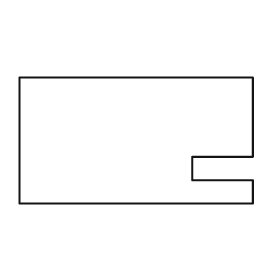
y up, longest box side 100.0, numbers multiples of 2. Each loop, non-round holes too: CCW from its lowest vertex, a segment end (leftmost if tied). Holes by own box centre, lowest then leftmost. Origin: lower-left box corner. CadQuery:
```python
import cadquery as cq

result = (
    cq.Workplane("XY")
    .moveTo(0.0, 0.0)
    .lineTo(100.0, 0.0)
    .lineTo(100.0, 10.0)
    .lineTo(74.0, 10.0)
    .lineTo(74.0, 20.0)
    .lineTo(100.0, 20.0)
    .lineTo(100.0, 54.0)
    .lineTo(0.0, 54.0)
    .close()
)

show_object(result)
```